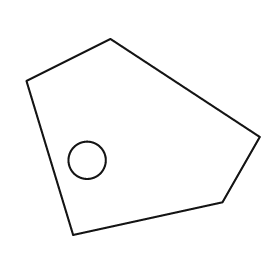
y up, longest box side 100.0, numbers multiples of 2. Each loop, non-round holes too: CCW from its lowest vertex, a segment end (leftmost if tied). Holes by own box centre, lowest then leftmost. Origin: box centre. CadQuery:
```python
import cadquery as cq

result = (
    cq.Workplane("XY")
    .moveTo(-30.0, -42.0)
    .lineTo(34.0, -28.0)
    .lineTo(50.0, 0.0)
    .lineTo(-14.0, 42.0)
    .lineTo(-50.0, 24.0)
    .close()
    .moveTo(-24.0, -10.0)
    .circle(8.0)
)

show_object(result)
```